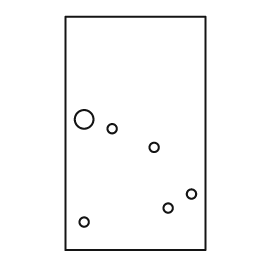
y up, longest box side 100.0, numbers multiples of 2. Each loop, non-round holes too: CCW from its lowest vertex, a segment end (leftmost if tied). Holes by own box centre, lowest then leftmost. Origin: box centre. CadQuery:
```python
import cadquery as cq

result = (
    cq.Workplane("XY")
    .moveTo(-30.0, -50.0)
    .lineTo(30.0, -50.0)
    .lineTo(30.0, 50.0)
    .lineTo(-30.0, 50.0)
    .close()
    .moveTo(-22.0, -38.0)
    .circle(2.0)
    .moveTo(14.0, -32.0)
    .circle(2.0)
    .moveTo(24.0, -26.0)
    .circle(2.0)
    .moveTo(8.0, -6.0)
    .circle(2.0)
    .moveTo(-10.0, 2.0)
    .circle(2.0)
    .moveTo(-22.0, 6.0)
    .circle(4.0)
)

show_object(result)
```